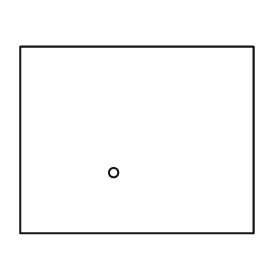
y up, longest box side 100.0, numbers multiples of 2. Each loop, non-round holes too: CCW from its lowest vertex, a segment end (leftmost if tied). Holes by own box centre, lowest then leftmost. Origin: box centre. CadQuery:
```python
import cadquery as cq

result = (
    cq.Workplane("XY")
    .moveTo(-50.0, -40.0)
    .lineTo(50.0, -40.0)
    .lineTo(50.0, 40.0)
    .lineTo(-50.0, 40.0)
    .close()
    .moveTo(-10.0, -14.0)
    .circle(2.0)
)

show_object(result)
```